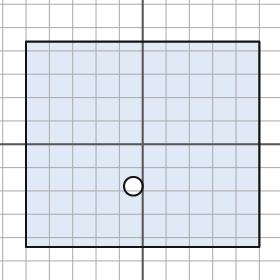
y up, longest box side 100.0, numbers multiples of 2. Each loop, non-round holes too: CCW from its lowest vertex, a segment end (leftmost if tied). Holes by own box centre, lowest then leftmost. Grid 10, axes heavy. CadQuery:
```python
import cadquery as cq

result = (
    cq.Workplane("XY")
    .moveTo(-50.0, -44.0)
    .lineTo(50.0, -44.0)
    .lineTo(50.0, 44.0)
    .lineTo(-50.0, 44.0)
    .close()
    .moveTo(-4.0, -18.0)
    .circle(4.0)
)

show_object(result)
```